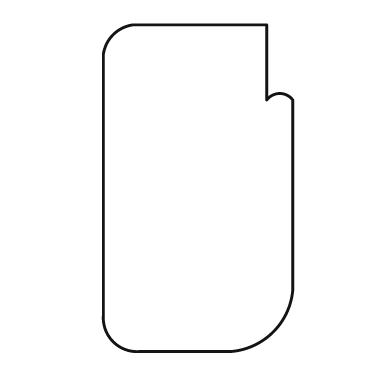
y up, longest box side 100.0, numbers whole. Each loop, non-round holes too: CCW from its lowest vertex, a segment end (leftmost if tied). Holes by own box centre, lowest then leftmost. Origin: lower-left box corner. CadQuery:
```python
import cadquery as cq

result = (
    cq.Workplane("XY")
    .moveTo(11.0, 0.0)
    .lineTo(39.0, 0.0)
    .threePointArc((52.0, 6.0), (58.0, 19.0))
    .lineTo(58.0, 77.0)
    .threePointArc((54.0, 79.0), (50.0, 77.0))
    .lineTo(50.0, 100.0)
    .lineTo(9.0, 100.0)
    .threePointArc((3.0, 97.0), (0.0, 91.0))
    .lineTo(0.0, 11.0)
    .threePointArc((3.0, 3.0), (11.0, 0.0))
    .close()
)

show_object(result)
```